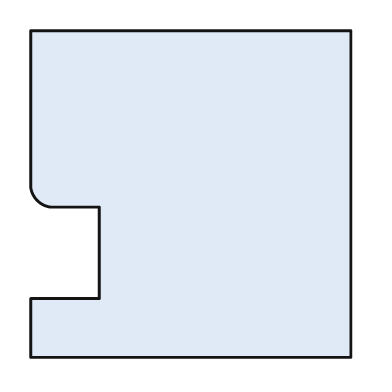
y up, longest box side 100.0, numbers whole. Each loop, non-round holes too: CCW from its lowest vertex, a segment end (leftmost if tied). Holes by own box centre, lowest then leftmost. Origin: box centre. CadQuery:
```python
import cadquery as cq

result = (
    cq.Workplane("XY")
    .moveTo(-49.0, -50.0)
    .lineTo(49.0, -50.0)
    .lineTo(49.0, 50.0)
    .lineTo(-49.0, 50.0)
    .lineTo(-49.0, 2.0)
    .threePointArc((-47.0, -2.0), (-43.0, -4.0))
    .lineTo(-28.0, -4.0)
    .lineTo(-28.0, -32.0)
    .lineTo(-49.0, -32.0)
    .close()
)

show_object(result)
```